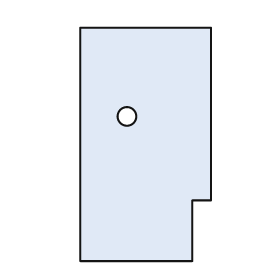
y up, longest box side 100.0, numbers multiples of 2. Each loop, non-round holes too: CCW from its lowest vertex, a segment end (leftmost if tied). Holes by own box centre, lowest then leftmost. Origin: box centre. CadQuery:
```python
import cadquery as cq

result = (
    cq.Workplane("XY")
    .moveTo(-28.0, -50.0)
    .lineTo(20.0, -50.0)
    .lineTo(20.0, -24.0)
    .lineTo(28.0, -24.0)
    .lineTo(28.0, 50.0)
    .lineTo(-28.0, 50.0)
    .close()
    .moveTo(-8.0, 12.0)
    .circle(4.0)
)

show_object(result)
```